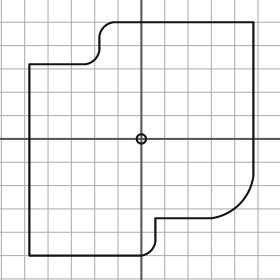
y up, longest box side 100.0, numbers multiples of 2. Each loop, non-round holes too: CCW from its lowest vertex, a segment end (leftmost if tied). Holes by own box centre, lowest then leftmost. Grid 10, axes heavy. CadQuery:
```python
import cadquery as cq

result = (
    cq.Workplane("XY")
    .moveTo(-48.0, -50.0)
    .lineTo(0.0, -50.0)
    .threePointArc((4.0, -48.0), (6.0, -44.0))
    .lineTo(6.0, -34.0)
    .lineTo(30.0, -34.0)
    .threePointArc((42.0, -28.0), (48.0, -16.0))
    .lineTo(48.0, 50.0)
    .lineTo(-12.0, 50.0)
    .threePointArc((-16.0, 48.0), (-18.0, 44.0))
    .lineTo(-18.0, 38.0)
    .threePointArc((-20.0, 34.0), (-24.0, 32.0))
    .lineTo(-48.0, 32.0)
    .close()
    .moveTo(0.0, 0.0)
    .circle(2.0)
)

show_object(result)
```